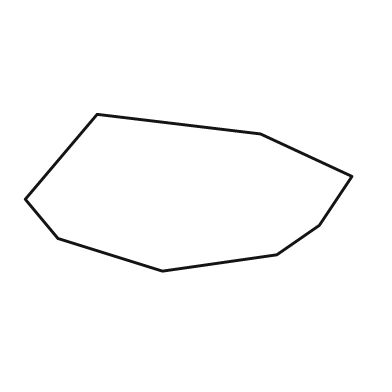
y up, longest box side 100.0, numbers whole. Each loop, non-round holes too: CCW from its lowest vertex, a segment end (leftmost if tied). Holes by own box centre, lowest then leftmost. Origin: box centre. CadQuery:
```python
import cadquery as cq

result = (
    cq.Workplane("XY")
    .moveTo(-8.0, -24.0)
    .lineTo(27.0, -19.0)
    .lineTo(40.0, -10.0)
    .lineTo(50.0, 5.0)
    .lineTo(22.0, 18.0)
    .lineTo(-28.0, 24.0)
    .lineTo(-50.0, -2.0)
    .lineTo(-40.0, -14.0)
    .close()
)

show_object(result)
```